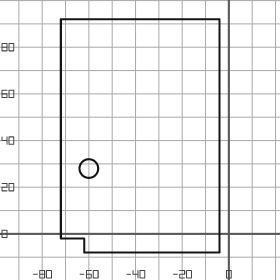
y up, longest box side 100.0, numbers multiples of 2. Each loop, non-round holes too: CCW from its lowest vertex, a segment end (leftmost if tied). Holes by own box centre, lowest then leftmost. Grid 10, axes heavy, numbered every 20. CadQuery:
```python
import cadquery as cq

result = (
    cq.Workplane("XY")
    .moveTo(-62.0, -8.0)
    .lineTo(-4.0, -8.0)
    .lineTo(-4.0, 92.0)
    .lineTo(-72.0, 92.0)
    .lineTo(-72.0, -2.0)
    .lineTo(-62.0, -2.0)
    .close()
    .moveTo(-60.0, 28.0)
    .circle(4.0)
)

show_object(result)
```